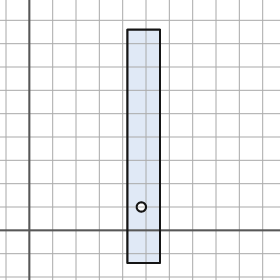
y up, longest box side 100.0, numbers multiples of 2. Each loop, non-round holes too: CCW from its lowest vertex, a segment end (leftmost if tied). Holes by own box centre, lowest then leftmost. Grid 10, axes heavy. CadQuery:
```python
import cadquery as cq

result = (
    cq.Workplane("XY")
    .moveTo(42.0, -14.0)
    .lineTo(56.0, -14.0)
    .lineTo(56.0, 86.0)
    .lineTo(42.0, 86.0)
    .close()
    .moveTo(48.0, 10.0)
    .circle(2.0)
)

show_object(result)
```